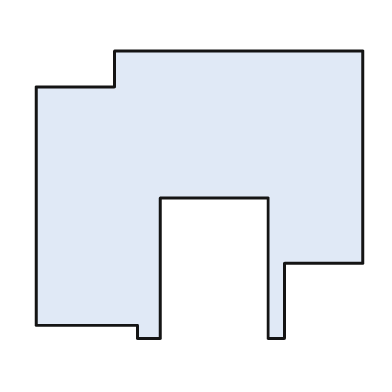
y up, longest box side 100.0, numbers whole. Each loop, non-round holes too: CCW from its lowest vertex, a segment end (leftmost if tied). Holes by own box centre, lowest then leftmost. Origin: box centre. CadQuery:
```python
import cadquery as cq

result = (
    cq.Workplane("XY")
    .moveTo(-19.0, -44.0)
    .lineTo(-12.0, -44.0)
    .lineTo(-12.0, -1.0)
    .lineTo(21.0, -1.0)
    .lineTo(21.0, -44.0)
    .lineTo(26.0, -44.0)
    .lineTo(26.0, -21.0)
    .lineTo(50.0, -21.0)
    .lineTo(50.0, 44.0)
    .lineTo(-26.0, 44.0)
    .lineTo(-26.0, 33.0)
    .lineTo(-50.0, 33.0)
    .lineTo(-50.0, -40.0)
    .lineTo(-19.0, -40.0)
    .close()
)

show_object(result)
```